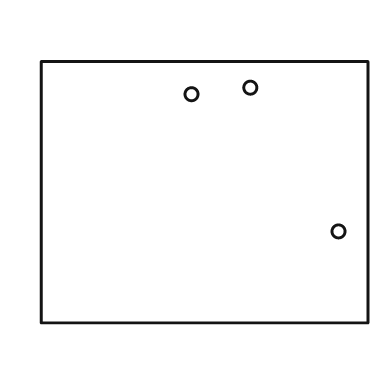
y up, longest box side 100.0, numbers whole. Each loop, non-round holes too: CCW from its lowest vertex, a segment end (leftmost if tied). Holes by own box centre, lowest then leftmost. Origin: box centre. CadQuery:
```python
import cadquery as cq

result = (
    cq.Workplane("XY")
    .moveTo(-50.0, -40.0)
    .lineTo(50.0, -40.0)
    .lineTo(50.0, 40.0)
    .lineTo(-50.0, 40.0)
    .close()
    .moveTo(41.0, -12.0)
    .circle(2.0)
    .moveTo(-4.0, 30.0)
    .circle(2.0)
    .moveTo(14.0, 32.0)
    .circle(2.0)
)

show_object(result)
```